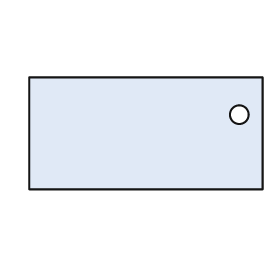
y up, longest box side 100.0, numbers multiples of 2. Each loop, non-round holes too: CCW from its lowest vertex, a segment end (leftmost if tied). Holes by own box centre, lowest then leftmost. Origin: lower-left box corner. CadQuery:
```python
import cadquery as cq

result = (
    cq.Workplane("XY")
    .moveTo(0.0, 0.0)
    .lineTo(100.0, 0.0)
    .lineTo(100.0, 48.0)
    .lineTo(0.0, 48.0)
    .close()
    .moveTo(90.0, 32.0)
    .circle(4.0)
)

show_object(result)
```